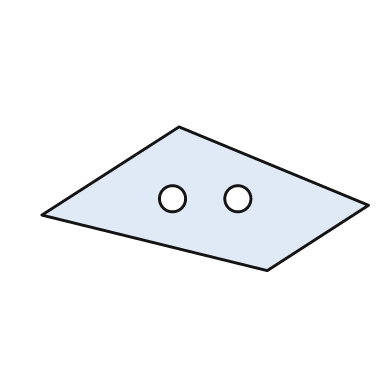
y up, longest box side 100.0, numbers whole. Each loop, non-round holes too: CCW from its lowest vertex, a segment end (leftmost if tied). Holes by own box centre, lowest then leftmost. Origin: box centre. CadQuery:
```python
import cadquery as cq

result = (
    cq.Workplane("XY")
    .moveTo(19.0, -22.0)
    .lineTo(50.0, -2.0)
    .lineTo(-8.0, 22.0)
    .lineTo(-50.0, -5.0)
    .close()
    .moveTo(-10.0, 0.0)
    .circle(4.0)
    .moveTo(10.0, 0.0)
    .circle(4.0)
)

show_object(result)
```